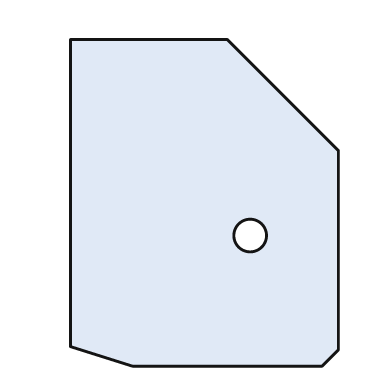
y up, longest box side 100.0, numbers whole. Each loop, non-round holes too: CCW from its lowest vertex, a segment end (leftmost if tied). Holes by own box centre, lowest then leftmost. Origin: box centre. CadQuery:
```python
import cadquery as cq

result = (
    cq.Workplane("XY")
    .moveTo(-22.0, -50.0)
    .lineTo(36.0, -50.0)
    .lineTo(41.0, -45.0)
    .lineTo(41.0, 16.0)
    .lineTo(7.0, 50.0)
    .lineTo(-41.0, 50.0)
    .lineTo(-41.0, -44.0)
    .close()
    .moveTo(14.0, -10.0)
    .circle(5.0)
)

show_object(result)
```